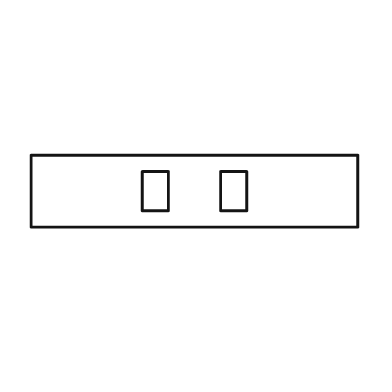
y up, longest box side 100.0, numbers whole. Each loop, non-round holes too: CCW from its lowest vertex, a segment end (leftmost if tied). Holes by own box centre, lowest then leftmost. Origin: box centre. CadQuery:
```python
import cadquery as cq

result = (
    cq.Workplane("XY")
    .moveTo(-50.0, -11.0)
    .lineTo(50.0, -11.0)
    .lineTo(50.0, 11.0)
    .lineTo(-50.0, 11.0)
    .close()
    .moveTo(-16.0, -6.0)
    .lineTo(-8.0, -6.0)
    .lineTo(-8.0, 6.0)
    .lineTo(-16.0, 6.0)
    .close()
    .moveTo(8.0, -6.0)
    .lineTo(16.0, -6.0)
    .lineTo(16.0, 6.0)
    .lineTo(8.0, 6.0)
    .close()
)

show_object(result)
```